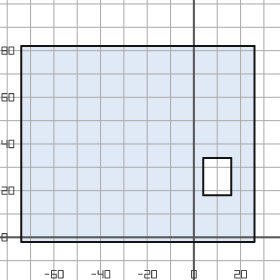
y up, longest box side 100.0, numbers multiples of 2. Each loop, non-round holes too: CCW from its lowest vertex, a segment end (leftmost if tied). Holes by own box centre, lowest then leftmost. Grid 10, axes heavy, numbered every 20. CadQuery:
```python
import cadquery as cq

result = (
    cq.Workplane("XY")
    .moveTo(-74.0, -2.0)
    .lineTo(26.0, -2.0)
    .lineTo(26.0, 82.0)
    .lineTo(-74.0, 82.0)
    .close()
    .moveTo(4.0, 18.0)
    .lineTo(16.0, 18.0)
    .lineTo(16.0, 34.0)
    .lineTo(4.0, 34.0)
    .close()
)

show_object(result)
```